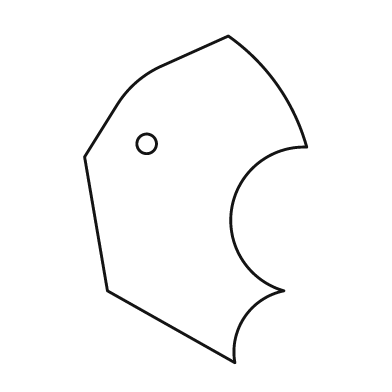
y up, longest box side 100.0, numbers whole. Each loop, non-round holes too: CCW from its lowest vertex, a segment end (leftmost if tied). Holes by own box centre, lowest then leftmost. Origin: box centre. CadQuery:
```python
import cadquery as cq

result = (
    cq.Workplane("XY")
    .moveTo(12.0, -50.0)
    .threePointArc((15.0, -36.0), (27.0, -28.0))
    .threePointArc((11.0, -3.0), (34.0, 16.0))
    .threePointArc((25.0, 35.0), (10.0, 50.0))
    .lineTo(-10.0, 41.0)
    .threePointArc((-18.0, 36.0), (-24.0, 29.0))
    .lineTo(-34.0, 13.0)
    .lineTo(-27.0, -28.0)
    .close()
    .moveTo(-15.0, 17.0)
    .circle(3.0)
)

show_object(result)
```